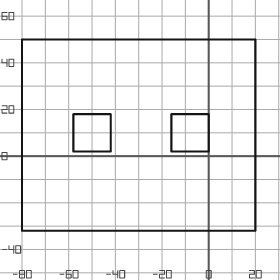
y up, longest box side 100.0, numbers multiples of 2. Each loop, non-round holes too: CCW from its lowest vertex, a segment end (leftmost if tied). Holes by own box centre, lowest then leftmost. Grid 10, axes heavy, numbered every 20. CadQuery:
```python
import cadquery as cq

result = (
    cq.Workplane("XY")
    .moveTo(-80.0, -32.0)
    .lineTo(20.0, -32.0)
    .lineTo(20.0, 50.0)
    .lineTo(-80.0, 50.0)
    .close()
    .moveTo(-58.0, 2.0)
    .lineTo(-42.0, 2.0)
    .lineTo(-42.0, 18.0)
    .lineTo(-58.0, 18.0)
    .close()
    .moveTo(-16.0, 2.0)
    .lineTo(0.0, 2.0)
    .lineTo(0.0, 18.0)
    .lineTo(-16.0, 18.0)
    .close()
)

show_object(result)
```